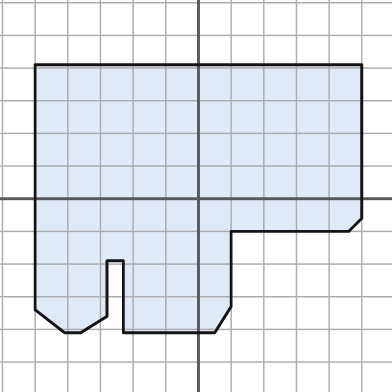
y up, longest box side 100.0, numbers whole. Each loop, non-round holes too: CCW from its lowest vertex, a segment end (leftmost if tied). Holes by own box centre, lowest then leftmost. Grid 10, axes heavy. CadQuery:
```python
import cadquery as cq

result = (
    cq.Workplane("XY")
    .moveTo(-41.0, -41.0)
    .lineTo(-36.0, -41.0)
    .lineTo(-28.0, -36.0)
    .lineTo(-28.0, -19.0)
    .lineTo(-23.0, -19.0)
    .lineTo(-23.0, -41.0)
    .lineTo(5.0, -41.0)
    .lineTo(10.0, -33.0)
    .lineTo(10.0, -10.0)
    .lineTo(46.0, -10.0)
    .lineTo(50.0, -6.0)
    .lineTo(50.0, 41.0)
    .lineTo(-50.0, 41.0)
    .lineTo(-50.0, -34.0)
    .close()
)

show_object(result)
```